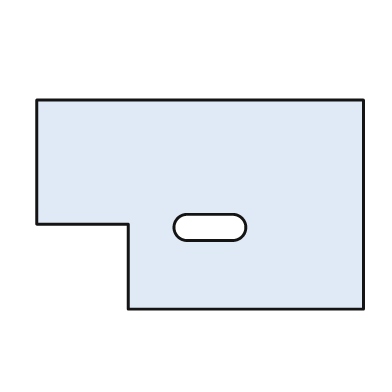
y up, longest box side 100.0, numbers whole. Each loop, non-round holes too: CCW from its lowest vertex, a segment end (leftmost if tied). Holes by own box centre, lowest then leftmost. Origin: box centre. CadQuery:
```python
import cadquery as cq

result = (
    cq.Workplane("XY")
    .moveTo(-22.0, -32.0)
    .lineTo(50.0, -32.0)
    .lineTo(50.0, 32.0)
    .lineTo(-50.0, 32.0)
    .lineTo(-50.0, -6.0)
    .lineTo(-22.0, -6.0)
    .close()
    .moveTo(-4.0, -11.0)
    .lineTo(10.0, -11.0)
    .threePointArc((14.0, -7.0), (10.0, -3.0))
    .lineTo(-4.0, -3.0)
    .threePointArc((-8.0, -7.0), (-4.0, -11.0))
    .close()
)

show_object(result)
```